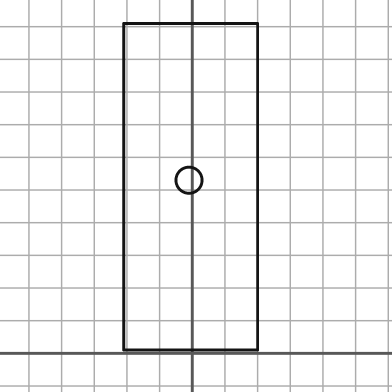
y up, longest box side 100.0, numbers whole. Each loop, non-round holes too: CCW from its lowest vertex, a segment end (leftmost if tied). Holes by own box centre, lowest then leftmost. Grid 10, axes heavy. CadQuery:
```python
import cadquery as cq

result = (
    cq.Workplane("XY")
    .moveTo(-21.0, 1.0)
    .lineTo(20.0, 1.0)
    .lineTo(20.0, 101.0)
    .lineTo(-21.0, 101.0)
    .close()
    .moveTo(-1.0, 53.0)
    .circle(4.0)
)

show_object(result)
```